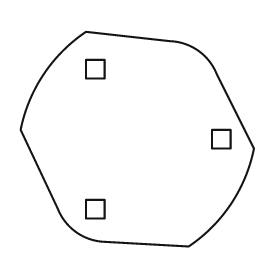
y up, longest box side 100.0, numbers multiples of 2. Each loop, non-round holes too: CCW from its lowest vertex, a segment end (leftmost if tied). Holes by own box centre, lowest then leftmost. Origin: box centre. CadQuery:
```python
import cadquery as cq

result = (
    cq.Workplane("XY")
    .moveTo(22.0, -46.0)
    .threePointArc((40.0, -28.0), (50.0, -4.0))
    .lineTo(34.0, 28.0)
    .threePointArc((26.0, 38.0), (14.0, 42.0))
    .lineTo(-22.0, 46.0)
    .threePointArc((-40.0, 28.0), (-50.0, 4.0))
    .lineTo(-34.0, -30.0)
    .threePointArc((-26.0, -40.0), (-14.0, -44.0))
    .close()
    .moveTo(-22.0, -34.0)
    .lineTo(-14.0, -34.0)
    .lineTo(-14.0, -26.0)
    .lineTo(-22.0, -26.0)
    .close()
    .moveTo(32.0, -4.0)
    .lineTo(40.0, -4.0)
    .lineTo(40.0, 4.0)
    .lineTo(32.0, 4.0)
    .close()
    .moveTo(-22.0, 26.0)
    .lineTo(-14.0, 26.0)
    .lineTo(-14.0, 34.0)
    .lineTo(-22.0, 34.0)
    .close()
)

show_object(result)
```